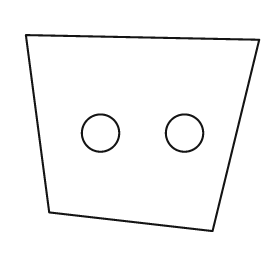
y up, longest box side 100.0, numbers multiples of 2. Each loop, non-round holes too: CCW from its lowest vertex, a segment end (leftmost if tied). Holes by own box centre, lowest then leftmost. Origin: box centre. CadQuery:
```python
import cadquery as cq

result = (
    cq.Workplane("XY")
    .moveTo(30.0, -42.0)
    .lineTo(50.0, 40.0)
    .lineTo(-50.0, 42.0)
    .lineTo(-40.0, -34.0)
    .close()
    .moveTo(-18.0, 0.0)
    .circle(8.0)
    .moveTo(18.0, 0.0)
    .circle(8.0)
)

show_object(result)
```